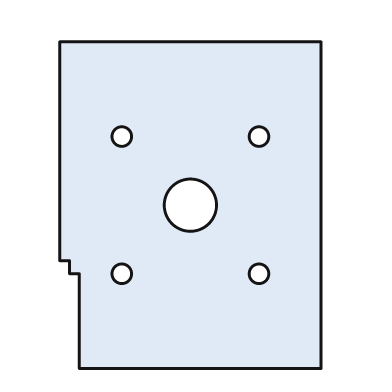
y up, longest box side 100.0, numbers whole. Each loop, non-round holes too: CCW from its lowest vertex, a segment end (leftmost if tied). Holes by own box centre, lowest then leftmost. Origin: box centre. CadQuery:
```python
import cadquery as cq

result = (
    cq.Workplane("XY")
    .moveTo(-34.0, -50.0)
    .lineTo(40.0, -50.0)
    .lineTo(40.0, 50.0)
    .lineTo(-40.0, 50.0)
    .lineTo(-40.0, -17.0)
    .lineTo(-37.0, -17.0)
    .lineTo(-37.0, -21.0)
    .lineTo(-34.0, -21.0)
    .close()
    .moveTo(-21.0, -21.0)
    .circle(3.0)
    .moveTo(21.0, -21.0)
    .circle(3.0)
    .moveTo(0.0, 0.0)
    .circle(8.0)
    .moveTo(-21.0, 21.0)
    .circle(3.0)
    .moveTo(21.0, 21.0)
    .circle(3.0)
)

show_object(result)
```